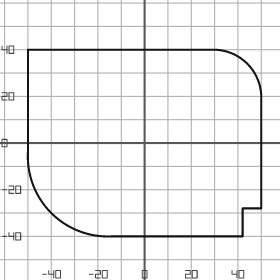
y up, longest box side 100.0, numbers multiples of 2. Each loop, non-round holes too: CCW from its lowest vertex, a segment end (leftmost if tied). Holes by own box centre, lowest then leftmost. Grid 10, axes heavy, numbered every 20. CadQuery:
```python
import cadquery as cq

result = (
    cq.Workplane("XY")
    .moveTo(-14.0, -40.0)
    .lineTo(42.0, -40.0)
    .lineTo(42.0, -28.0)
    .lineTo(50.0, -28.0)
    .lineTo(50.0, 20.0)
    .threePointArc((44.0, 34.0), (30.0, 40.0))
    .lineTo(-50.0, 40.0)
    .lineTo(-50.0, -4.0)
    .threePointArc((-40.0, -30.0), (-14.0, -40.0))
    .close()
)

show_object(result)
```